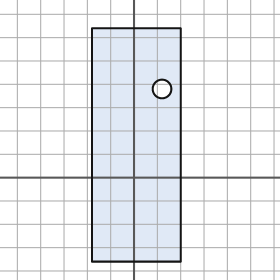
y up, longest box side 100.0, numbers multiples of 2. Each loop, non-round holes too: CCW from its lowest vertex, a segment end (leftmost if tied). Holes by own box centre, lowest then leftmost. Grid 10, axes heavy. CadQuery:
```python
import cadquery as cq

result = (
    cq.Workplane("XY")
    .moveTo(-18.0, -36.0)
    .lineTo(20.0, -36.0)
    .lineTo(20.0, 64.0)
    .lineTo(-18.0, 64.0)
    .close()
    .moveTo(12.0, 38.0)
    .circle(4.0)
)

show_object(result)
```